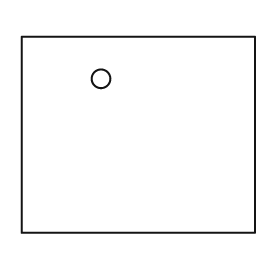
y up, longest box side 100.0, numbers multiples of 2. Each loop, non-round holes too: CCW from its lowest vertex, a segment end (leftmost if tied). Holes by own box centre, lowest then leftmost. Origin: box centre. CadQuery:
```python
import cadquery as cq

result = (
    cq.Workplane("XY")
    .moveTo(-50.0, -42.0)
    .lineTo(50.0, -42.0)
    .lineTo(50.0, 42.0)
    .lineTo(-50.0, 42.0)
    .close()
    .moveTo(-16.0, 24.0)
    .circle(4.0)
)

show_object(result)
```